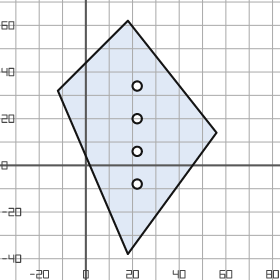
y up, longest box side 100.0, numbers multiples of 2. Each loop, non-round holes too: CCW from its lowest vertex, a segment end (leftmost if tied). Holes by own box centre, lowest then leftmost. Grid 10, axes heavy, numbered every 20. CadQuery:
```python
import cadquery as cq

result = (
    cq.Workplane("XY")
    .moveTo(18.0, -38.0)
    .lineTo(56.0, 14.0)
    .lineTo(18.0, 62.0)
    .lineTo(-12.0, 32.0)
    .close()
    .moveTo(22.0, -8.0)
    .circle(2.0)
    .moveTo(22.0, 6.0)
    .circle(2.0)
    .moveTo(22.0, 20.0)
    .circle(2.0)
    .moveTo(22.0, 34.0)
    .circle(2.0)
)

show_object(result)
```